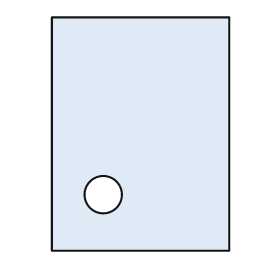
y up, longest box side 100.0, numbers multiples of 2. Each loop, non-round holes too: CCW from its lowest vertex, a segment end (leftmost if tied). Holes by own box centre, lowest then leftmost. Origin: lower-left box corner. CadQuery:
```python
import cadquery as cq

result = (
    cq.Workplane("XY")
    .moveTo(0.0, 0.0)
    .lineTo(76.0, 0.0)
    .lineTo(76.0, 100.0)
    .lineTo(0.0, 100.0)
    .close()
    .moveTo(22.0, 24.0)
    .circle(8.0)
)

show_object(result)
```